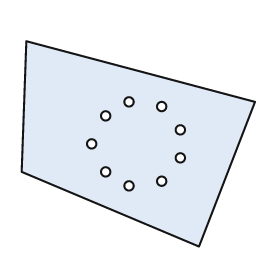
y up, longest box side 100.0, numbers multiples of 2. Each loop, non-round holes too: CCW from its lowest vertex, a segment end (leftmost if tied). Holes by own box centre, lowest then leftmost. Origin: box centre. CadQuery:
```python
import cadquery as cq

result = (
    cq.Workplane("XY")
    .moveTo(26.0, -44.0)
    .lineTo(50.0, 18.0)
    .lineTo(-48.0, 44.0)
    .lineTo(-50.0, -12.0)
    .close()
    .moveTo(-4.0, -18.0)
    .circle(2.0)
    .moveTo(10.0, -16.0)
    .circle(2.0)
    .moveTo(-14.0, -12.0)
    .circle(2.0)
    .moveTo(18.0, -6.0)
    .circle(2.0)
    .moveTo(-20.0, 0.0)
    .circle(2.0)
    .moveTo(18.0, 6.0)
    .circle(2.0)
    .moveTo(-14.0, 12.0)
    .circle(2.0)
    .moveTo(10.0, 16.0)
    .circle(2.0)
    .moveTo(-4.0, 18.0)
    .circle(2.0)
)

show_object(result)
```